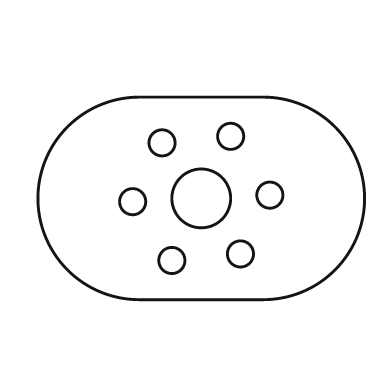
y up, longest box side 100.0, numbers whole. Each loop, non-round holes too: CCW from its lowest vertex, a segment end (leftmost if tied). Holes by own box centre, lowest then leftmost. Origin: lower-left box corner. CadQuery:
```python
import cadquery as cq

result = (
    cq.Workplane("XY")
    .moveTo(31.0, 0.0)
    .lineTo(69.0, 0.0)
    .threePointArc((100.0, 31.0), (69.0, 62.0))
    .lineTo(31.0, 62.0)
    .threePointArc((0.0, 31.0), (31.0, 0.0))
    .close()
    .moveTo(41.0, 12.0)
    .circle(4.0)
    .moveTo(62.0, 14.0)
    .circle(4.0)
    .moveTo(29.0, 30.0)
    .circle(4.0)
    .moveTo(50.0, 31.0)
    .circle(9.0)
    .moveTo(71.0, 32.0)
    .circle(4.0)
    .moveTo(38.0, 48.0)
    .circle(4.0)
    .moveTo(59.0, 50.0)
    .circle(4.0)
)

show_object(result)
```